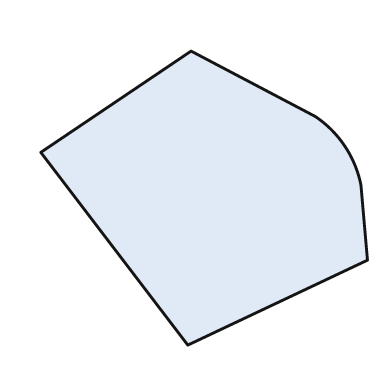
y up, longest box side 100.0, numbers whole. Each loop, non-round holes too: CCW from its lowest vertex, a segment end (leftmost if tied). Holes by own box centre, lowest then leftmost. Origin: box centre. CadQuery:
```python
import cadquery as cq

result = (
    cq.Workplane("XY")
    .moveTo(-5.0, -45.0)
    .lineTo(50.0, -19.0)
    .lineTo(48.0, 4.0)
    .threePointArc((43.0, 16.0), (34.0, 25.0))
    .lineTo(-4.0, 45.0)
    .lineTo(-50.0, 14.0)
    .close()
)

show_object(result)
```